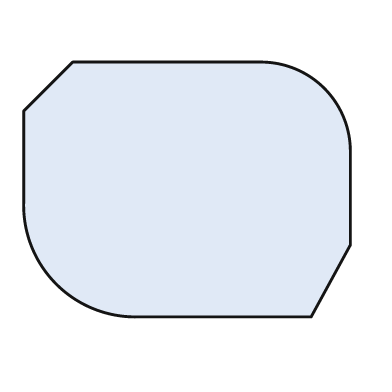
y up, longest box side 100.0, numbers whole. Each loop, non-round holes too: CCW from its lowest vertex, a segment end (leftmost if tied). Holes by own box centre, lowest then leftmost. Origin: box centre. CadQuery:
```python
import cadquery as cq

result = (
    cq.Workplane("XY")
    .moveTo(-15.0, -39.0)
    .lineTo(38.0, -39.0)
    .lineTo(50.0, -17.0)
    .lineTo(50.0, 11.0)
    .threePointArc((42.0, 31.0), (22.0, 39.0))
    .lineTo(-35.0, 39.0)
    .lineTo(-50.0, 24.0)
    .lineTo(-50.0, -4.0)
    .threePointArc((-40.0, -29.0), (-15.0, -39.0))
    .close()
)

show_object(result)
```